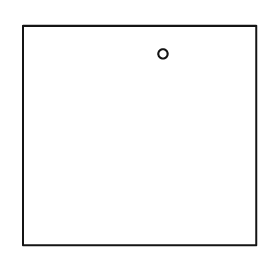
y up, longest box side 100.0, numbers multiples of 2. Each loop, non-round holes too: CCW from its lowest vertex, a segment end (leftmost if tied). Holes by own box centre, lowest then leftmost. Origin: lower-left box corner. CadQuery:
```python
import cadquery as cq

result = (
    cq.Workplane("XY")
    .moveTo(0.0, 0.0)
    .lineTo(100.0, 0.0)
    .lineTo(100.0, 94.0)
    .lineTo(0.0, 94.0)
    .close()
    .moveTo(60.0, 82.0)
    .circle(2.0)
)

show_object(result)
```